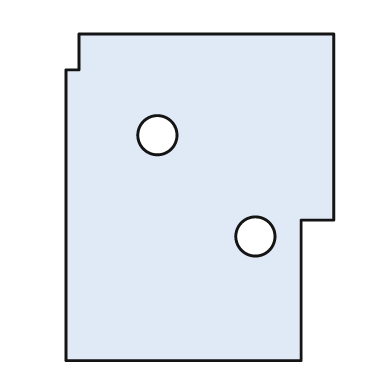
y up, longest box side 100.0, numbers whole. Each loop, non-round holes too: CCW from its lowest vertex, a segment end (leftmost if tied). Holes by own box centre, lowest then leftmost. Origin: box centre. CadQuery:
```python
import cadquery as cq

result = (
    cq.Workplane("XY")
    .moveTo(-41.0, -50.0)
    .lineTo(31.0, -50.0)
    .lineTo(31.0, -7.0)
    .lineTo(41.0, -7.0)
    .lineTo(41.0, 50.0)
    .lineTo(-37.0, 50.0)
    .lineTo(-37.0, 39.0)
    .lineTo(-41.0, 39.0)
    .close()
    .moveTo(17.0, -12.0)
    .circle(6.0)
    .moveTo(-13.0, 19.0)
    .circle(6.0)
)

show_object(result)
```